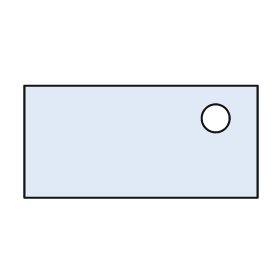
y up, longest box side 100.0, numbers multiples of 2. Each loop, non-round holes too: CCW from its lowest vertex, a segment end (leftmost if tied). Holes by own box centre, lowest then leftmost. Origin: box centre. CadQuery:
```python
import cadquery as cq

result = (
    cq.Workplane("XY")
    .moveTo(-50.0, -24.0)
    .lineTo(50.0, -24.0)
    .lineTo(50.0, 24.0)
    .lineTo(-50.0, 24.0)
    .close()
    .moveTo(32.0, 10.0)
    .circle(6.0)
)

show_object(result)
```